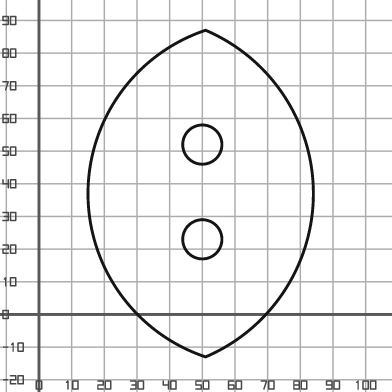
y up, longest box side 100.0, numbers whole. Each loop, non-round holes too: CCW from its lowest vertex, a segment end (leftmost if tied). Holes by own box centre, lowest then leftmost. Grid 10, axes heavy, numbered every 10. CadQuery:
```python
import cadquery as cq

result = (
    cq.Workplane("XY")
    .moveTo(51.0, -13.0)
    .threePointArc((84.0, 37.0), (51.0, 87.0))
    .threePointArc((15.0, 37.0), (51.0, -13.0))
    .close()
    .moveTo(50.0, 23.0)
    .circle(6.0)
    .moveTo(50.0, 52.0)
    .circle(6.0)
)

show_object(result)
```